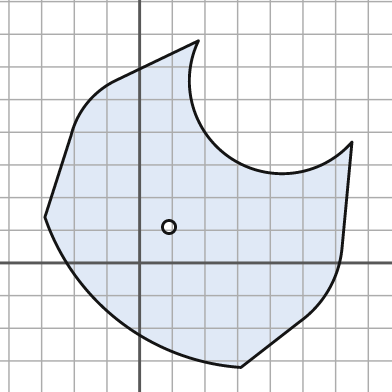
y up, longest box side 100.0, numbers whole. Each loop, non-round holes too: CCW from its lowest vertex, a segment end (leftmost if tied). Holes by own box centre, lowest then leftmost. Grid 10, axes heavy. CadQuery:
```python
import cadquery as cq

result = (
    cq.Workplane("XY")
    .moveTo(31.0, -32.0)
    .lineTo(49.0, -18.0)
    .threePointArc((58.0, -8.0), (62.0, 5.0))
    .lineTo(65.0, 37.0)
    .threePointArc((28.0, 32.0), (18.0, 68.0))
    .lineTo(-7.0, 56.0)
    .threePointArc((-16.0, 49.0), (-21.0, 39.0))
    .lineTo(-29.0, 14.0)
    .threePointArc((-6.0, -18.0), (31.0, -32.0))
    .close()
    .moveTo(9.0, 11.0)
    .circle(2.0)
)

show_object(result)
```